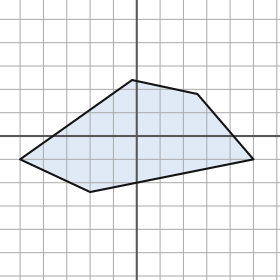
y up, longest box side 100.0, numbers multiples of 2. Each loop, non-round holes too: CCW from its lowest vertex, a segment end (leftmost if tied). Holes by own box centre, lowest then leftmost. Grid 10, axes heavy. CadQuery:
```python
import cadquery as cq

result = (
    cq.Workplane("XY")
    .moveTo(-20.0, -24.0)
    .lineTo(50.0, -10.0)
    .lineTo(26.0, 18.0)
    .lineTo(-2.0, 24.0)
    .lineTo(-50.0, -10.0)
    .close()
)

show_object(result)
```